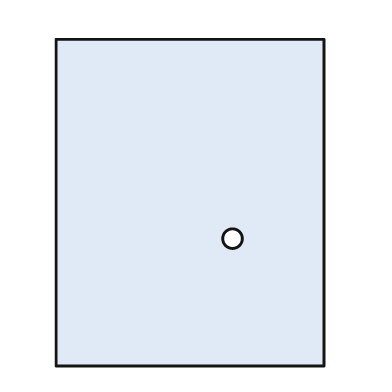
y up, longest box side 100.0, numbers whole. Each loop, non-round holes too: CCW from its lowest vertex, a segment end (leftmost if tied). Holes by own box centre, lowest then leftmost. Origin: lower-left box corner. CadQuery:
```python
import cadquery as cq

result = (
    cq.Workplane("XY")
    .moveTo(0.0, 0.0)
    .lineTo(82.0, 0.0)
    .lineTo(82.0, 100.0)
    .lineTo(0.0, 100.0)
    .close()
    .moveTo(54.0, 39.0)
    .circle(3.0)
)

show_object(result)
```